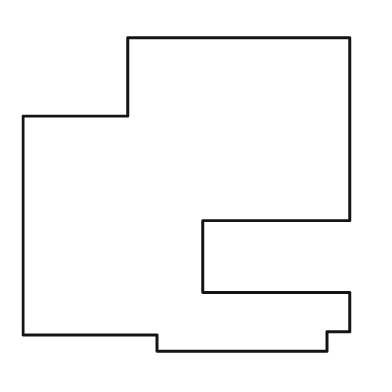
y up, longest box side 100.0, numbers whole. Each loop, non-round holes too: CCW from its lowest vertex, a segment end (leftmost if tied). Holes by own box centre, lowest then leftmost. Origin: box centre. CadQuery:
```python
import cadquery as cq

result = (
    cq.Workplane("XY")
    .moveTo(-9.0, -48.0)
    .lineTo(43.0, -48.0)
    .lineTo(43.0, -42.0)
    .lineTo(50.0, -42.0)
    .lineTo(50.0, -30.0)
    .lineTo(5.0, -30.0)
    .lineTo(5.0, -8.0)
    .lineTo(50.0, -8.0)
    .lineTo(50.0, 48.0)
    .lineTo(-18.0, 48.0)
    .lineTo(-18.0, 24.0)
    .lineTo(-50.0, 24.0)
    .lineTo(-50.0, -43.0)
    .lineTo(-9.0, -43.0)
    .close()
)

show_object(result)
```